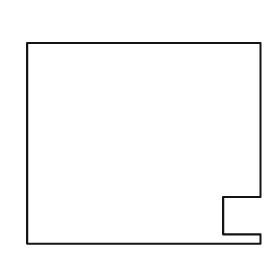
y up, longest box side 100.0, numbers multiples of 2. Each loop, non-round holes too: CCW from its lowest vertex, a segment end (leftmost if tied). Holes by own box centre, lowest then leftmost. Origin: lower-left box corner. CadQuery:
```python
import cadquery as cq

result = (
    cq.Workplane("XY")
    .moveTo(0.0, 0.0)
    .lineTo(100.0, 0.0)
    .lineTo(100.0, 4.0)
    .lineTo(84.0, 4.0)
    .lineTo(84.0, 20.0)
    .lineTo(100.0, 20.0)
    .lineTo(100.0, 86.0)
    .lineTo(0.0, 86.0)
    .close()
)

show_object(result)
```